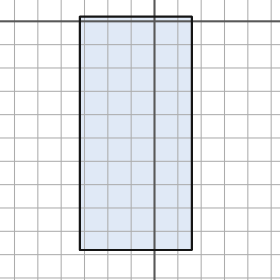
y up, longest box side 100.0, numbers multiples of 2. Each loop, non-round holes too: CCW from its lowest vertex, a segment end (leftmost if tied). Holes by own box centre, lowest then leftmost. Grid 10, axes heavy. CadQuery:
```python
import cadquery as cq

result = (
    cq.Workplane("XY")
    .moveTo(-32.0, -98.0)
    .lineTo(16.0, -98.0)
    .lineTo(16.0, 2.0)
    .lineTo(-32.0, 2.0)
    .close()
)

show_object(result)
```